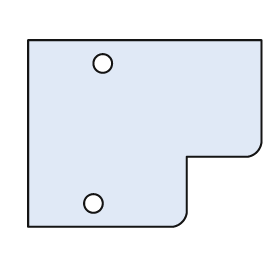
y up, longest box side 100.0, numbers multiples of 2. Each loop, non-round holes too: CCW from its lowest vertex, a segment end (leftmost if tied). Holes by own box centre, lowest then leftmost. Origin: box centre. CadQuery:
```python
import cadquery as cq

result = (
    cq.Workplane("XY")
    .moveTo(-50.0, -40.0)
    .lineTo(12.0, -40.0)
    .threePointArc((16.0, -38.0), (18.0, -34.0))
    .lineTo(18.0, -10.0)
    .lineTo(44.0, -10.0)
    .threePointArc((48.0, -8.0), (50.0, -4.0))
    .lineTo(50.0, 40.0)
    .lineTo(-50.0, 40.0)
    .close()
    .moveTo(-22.0, -30.0)
    .circle(4.0)
    .moveTo(-18.0, 30.0)
    .circle(4.0)
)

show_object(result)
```